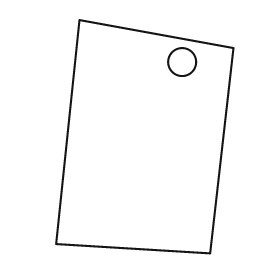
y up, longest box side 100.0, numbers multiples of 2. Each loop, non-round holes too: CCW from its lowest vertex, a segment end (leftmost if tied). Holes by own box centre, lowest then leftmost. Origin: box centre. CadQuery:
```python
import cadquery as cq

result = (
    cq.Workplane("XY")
    .moveTo(28.0, -50.0)
    .lineTo(38.0, 38.0)
    .lineTo(-28.0, 50.0)
    .lineTo(-38.0, -46.0)
    .close()
    .moveTo(16.0, 32.0)
    .circle(6.0)
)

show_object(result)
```